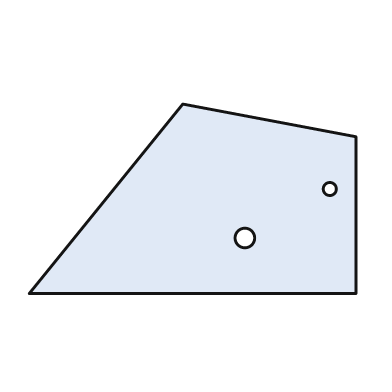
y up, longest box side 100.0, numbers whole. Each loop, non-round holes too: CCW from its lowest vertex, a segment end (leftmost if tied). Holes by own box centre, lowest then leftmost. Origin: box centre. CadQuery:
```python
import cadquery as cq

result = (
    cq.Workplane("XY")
    .moveTo(-50.0, -29.0)
    .lineTo(50.0, -29.0)
    .lineTo(50.0, 19.0)
    .lineTo(-3.0, 29.0)
    .close()
    .moveTo(16.0, -12.0)
    .circle(3.0)
    .moveTo(42.0, 3.0)
    .circle(2.0)
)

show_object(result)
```